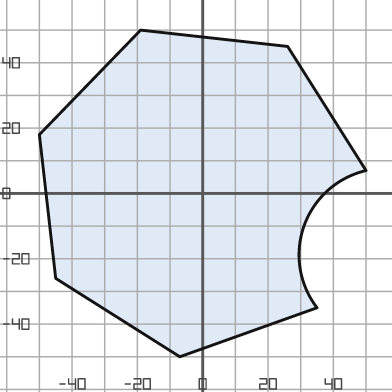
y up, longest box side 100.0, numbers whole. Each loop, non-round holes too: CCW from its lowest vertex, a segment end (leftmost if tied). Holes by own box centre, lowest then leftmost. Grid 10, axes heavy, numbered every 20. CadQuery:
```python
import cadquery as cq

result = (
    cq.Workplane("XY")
    .moveTo(-7.0, -50.0)
    .lineTo(35.0, -35.0)
    .threePointArc((31.0, -10.0), (50.0, 7.0))
    .lineTo(26.0, 45.0)
    .lineTo(-19.0, 50.0)
    .lineTo(-50.0, 18.0)
    .lineTo(-45.0, -26.0)
    .close()
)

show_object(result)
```